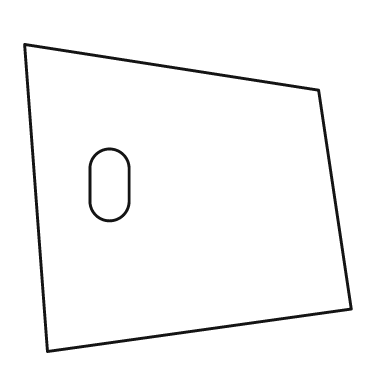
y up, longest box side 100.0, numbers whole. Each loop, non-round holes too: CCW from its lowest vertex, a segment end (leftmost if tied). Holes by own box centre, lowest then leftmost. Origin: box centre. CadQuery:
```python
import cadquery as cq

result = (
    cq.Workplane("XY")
    .moveTo(-43.0, -47.0)
    .lineTo(50.0, -34.0)
    .lineTo(40.0, 33.0)
    .lineTo(-50.0, 47.0)
    .close()
    .moveTo(-30.0, -1.0)
    .threePointArc((-24.0, -7.0), (-18.0, -1.0))
    .lineTo(-18.0, 9.0)
    .threePointArc((-24.0, 15.0), (-30.0, 9.0))
    .close()
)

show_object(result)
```